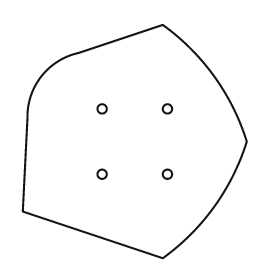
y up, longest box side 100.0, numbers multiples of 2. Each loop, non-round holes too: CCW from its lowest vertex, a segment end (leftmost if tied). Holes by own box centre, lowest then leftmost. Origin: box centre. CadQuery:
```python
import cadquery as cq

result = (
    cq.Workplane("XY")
    .moveTo(12.0, -50.0)
    .threePointArc((34.0, -28.0), (48.0, 0.0))
    .threePointArc((34.0, 28.0), (12.0, 50.0))
    .lineTo(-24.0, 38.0)
    .threePointArc((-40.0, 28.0), (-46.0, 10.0))
    .lineTo(-48.0, -30.0)
    .close()
    .moveTo(-14.0, -14.0)
    .circle(2.0)
    .moveTo(14.0, -14.0)
    .circle(2.0)
    .moveTo(-14.0, 14.0)
    .circle(2.0)
    .moveTo(14.0, 14.0)
    .circle(2.0)
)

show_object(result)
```